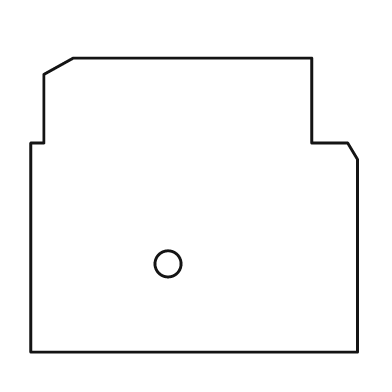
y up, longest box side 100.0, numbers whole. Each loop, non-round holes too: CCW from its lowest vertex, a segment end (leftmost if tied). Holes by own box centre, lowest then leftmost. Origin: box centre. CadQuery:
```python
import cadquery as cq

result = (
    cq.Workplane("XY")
    .moveTo(-50.0, -45.0)
    .lineTo(50.0, -45.0)
    .lineTo(50.0, 14.0)
    .lineTo(47.0, 19.0)
    .lineTo(36.0, 19.0)
    .lineTo(36.0, 45.0)
    .lineTo(-37.0, 45.0)
    .lineTo(-46.0, 40.0)
    .lineTo(-46.0, 19.0)
    .lineTo(-50.0, 19.0)
    .close()
    .moveTo(-8.0, -18.0)
    .circle(4.0)
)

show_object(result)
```